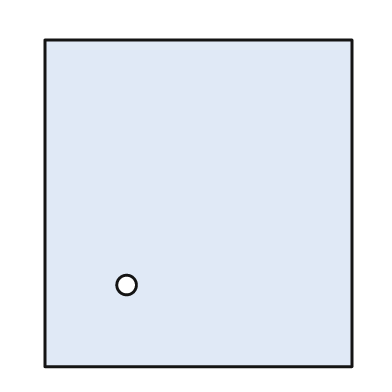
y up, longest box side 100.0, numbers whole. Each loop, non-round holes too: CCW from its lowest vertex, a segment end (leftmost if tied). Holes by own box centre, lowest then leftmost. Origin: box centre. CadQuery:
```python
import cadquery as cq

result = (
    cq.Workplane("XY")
    .moveTo(-47.0, -50.0)
    .lineTo(47.0, -50.0)
    .lineTo(47.0, 50.0)
    .lineTo(-47.0, 50.0)
    .close()
    .moveTo(-22.0, -25.0)
    .circle(3.0)
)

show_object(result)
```